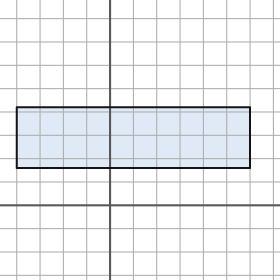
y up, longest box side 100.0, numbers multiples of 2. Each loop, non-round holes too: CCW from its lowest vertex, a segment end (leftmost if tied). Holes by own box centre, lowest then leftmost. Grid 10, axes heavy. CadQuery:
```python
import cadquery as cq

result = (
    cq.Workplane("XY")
    .moveTo(-40.0, 16.0)
    .lineTo(60.0, 16.0)
    .lineTo(60.0, 42.0)
    .lineTo(-40.0, 42.0)
    .close()
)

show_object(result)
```